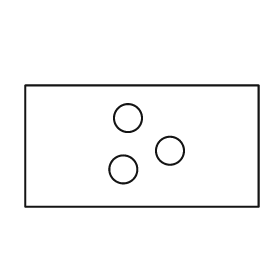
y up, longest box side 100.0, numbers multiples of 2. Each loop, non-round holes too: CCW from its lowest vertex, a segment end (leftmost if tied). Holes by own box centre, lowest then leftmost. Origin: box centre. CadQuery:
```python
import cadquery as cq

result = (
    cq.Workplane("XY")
    .moveTo(-50.0, -26.0)
    .lineTo(50.0, -26.0)
    .lineTo(50.0, 26.0)
    .lineTo(-50.0, 26.0)
    .close()
    .moveTo(-8.0, -10.0)
    .circle(6.0)
    .moveTo(12.0, -2.0)
    .circle(6.0)
    .moveTo(-6.0, 12.0)
    .circle(6.0)
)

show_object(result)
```